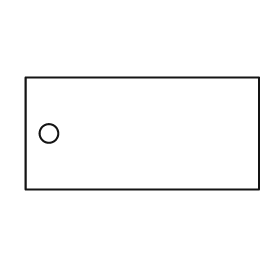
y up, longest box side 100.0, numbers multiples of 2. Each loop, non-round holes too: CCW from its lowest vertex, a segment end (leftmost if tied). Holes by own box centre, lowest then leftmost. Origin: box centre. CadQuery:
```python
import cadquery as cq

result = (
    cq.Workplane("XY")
    .moveTo(-50.0, -24.0)
    .lineTo(50.0, -24.0)
    .lineTo(50.0, 24.0)
    .lineTo(-50.0, 24.0)
    .close()
    .moveTo(-40.0, 0.0)
    .circle(4.0)
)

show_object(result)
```